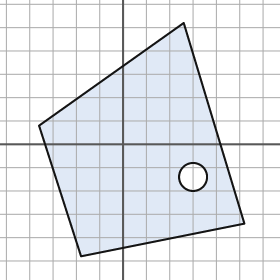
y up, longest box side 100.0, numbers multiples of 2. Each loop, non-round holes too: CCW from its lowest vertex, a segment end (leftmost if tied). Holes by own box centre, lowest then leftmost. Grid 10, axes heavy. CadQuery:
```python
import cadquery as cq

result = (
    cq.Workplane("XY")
    .moveTo(-18.0, -48.0)
    .lineTo(52.0, -34.0)
    .lineTo(26.0, 52.0)
    .lineTo(-36.0, 8.0)
    .close()
    .moveTo(30.0, -14.0)
    .circle(6.0)
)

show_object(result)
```